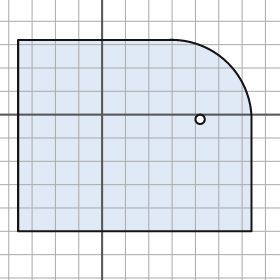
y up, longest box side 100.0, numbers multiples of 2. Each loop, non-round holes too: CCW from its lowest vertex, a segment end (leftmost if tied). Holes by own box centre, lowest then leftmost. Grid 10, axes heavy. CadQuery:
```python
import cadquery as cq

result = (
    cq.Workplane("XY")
    .moveTo(-36.0, -50.0)
    .lineTo(64.0, -50.0)
    .lineTo(64.0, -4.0)
    .threePointArc((54.0, 22.0), (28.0, 32.0))
    .lineTo(-36.0, 32.0)
    .close()
    .moveTo(42.0, -2.0)
    .circle(2.0)
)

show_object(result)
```